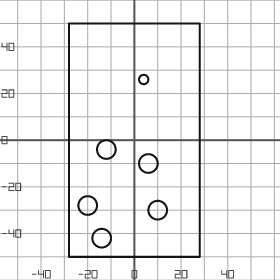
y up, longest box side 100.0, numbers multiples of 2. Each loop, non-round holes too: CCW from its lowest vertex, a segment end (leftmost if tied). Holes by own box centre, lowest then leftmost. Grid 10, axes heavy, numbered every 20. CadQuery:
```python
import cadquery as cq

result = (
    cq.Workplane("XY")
    .moveTo(-28.0, -50.0)
    .lineTo(28.0, -50.0)
    .lineTo(28.0, 50.0)
    .lineTo(-28.0, 50.0)
    .close()
    .moveTo(-14.0, -42.0)
    .circle(4.0)
    .moveTo(10.0, -30.0)
    .circle(4.0)
    .moveTo(-20.0, -28.0)
    .circle(4.0)
    .moveTo(6.0, -10.0)
    .circle(4.0)
    .moveTo(-12.0, -4.0)
    .circle(4.0)
    .moveTo(4.0, 26.0)
    .circle(2.0)
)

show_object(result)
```